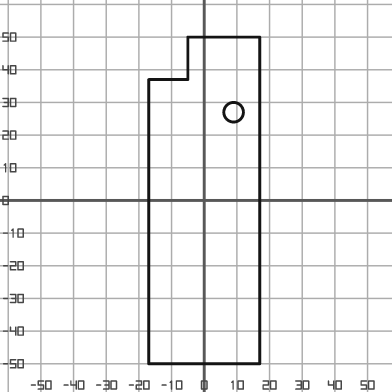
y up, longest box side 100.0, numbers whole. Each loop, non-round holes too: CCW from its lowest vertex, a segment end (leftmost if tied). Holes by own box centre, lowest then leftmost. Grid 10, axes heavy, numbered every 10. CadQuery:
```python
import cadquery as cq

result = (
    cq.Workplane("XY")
    .moveTo(-17.0, -50.0)
    .lineTo(17.0, -50.0)
    .lineTo(17.0, 50.0)
    .lineTo(-5.0, 50.0)
    .lineTo(-5.0, 37.0)
    .lineTo(-17.0, 37.0)
    .close()
    .moveTo(9.0, 27.0)
    .circle(3.0)
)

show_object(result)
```